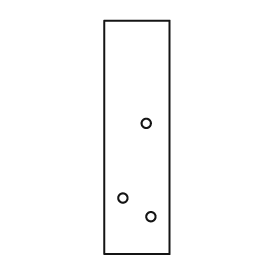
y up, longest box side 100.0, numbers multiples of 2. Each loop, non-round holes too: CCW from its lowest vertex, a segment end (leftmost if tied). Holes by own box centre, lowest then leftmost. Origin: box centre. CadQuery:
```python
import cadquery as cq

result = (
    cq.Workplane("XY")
    .moveTo(-14.0, -50.0)
    .lineTo(14.0, -50.0)
    .lineTo(14.0, 50.0)
    .lineTo(-14.0, 50.0)
    .close()
    .moveTo(6.0, -34.0)
    .circle(2.0)
    .moveTo(-6.0, -26.0)
    .circle(2.0)
    .moveTo(4.0, 6.0)
    .circle(2.0)
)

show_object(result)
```